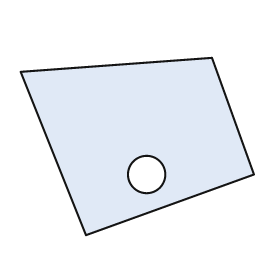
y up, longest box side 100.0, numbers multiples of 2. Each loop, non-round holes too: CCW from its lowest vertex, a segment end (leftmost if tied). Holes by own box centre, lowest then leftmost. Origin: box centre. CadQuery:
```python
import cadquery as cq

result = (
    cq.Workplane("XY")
    .moveTo(-22.0, -38.0)
    .lineTo(50.0, -12.0)
    .lineTo(32.0, 38.0)
    .lineTo(-50.0, 32.0)
    .close()
    .moveTo(4.0, -12.0)
    .circle(8.0)
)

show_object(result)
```